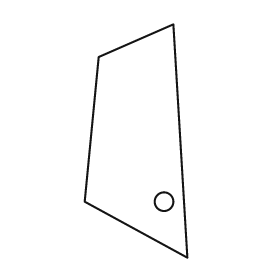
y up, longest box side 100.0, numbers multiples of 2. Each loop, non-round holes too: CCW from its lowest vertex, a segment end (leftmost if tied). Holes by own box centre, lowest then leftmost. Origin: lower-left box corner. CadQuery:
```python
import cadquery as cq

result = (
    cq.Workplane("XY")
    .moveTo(44.0, 0.0)
    .lineTo(38.0, 100.0)
    .lineTo(6.0, 86.0)
    .lineTo(0.0, 24.0)
    .close()
    .moveTo(34.0, 24.0)
    .circle(4.0)
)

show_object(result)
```